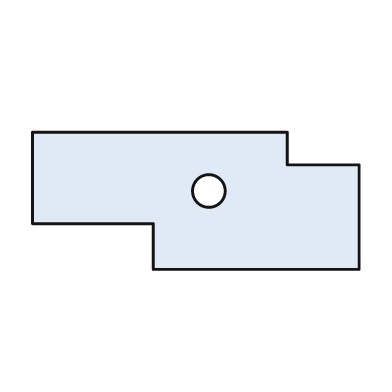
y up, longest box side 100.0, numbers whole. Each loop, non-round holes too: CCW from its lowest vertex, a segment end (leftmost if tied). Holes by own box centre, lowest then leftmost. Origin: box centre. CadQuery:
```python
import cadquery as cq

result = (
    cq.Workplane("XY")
    .moveTo(-13.0, -21.0)
    .lineTo(50.0, -21.0)
    .lineTo(50.0, 11.0)
    .lineTo(28.0, 11.0)
    .lineTo(28.0, 21.0)
    .lineTo(-50.0, 21.0)
    .lineTo(-50.0, -7.0)
    .lineTo(-13.0, -7.0)
    .close()
    .moveTo(4.0, 3.0)
    .circle(5.0)
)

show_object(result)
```